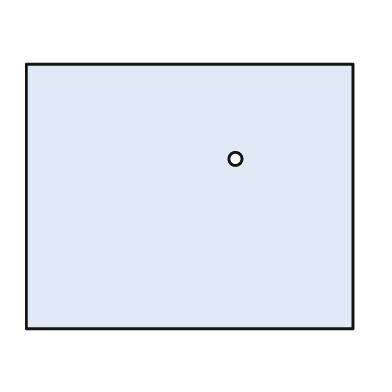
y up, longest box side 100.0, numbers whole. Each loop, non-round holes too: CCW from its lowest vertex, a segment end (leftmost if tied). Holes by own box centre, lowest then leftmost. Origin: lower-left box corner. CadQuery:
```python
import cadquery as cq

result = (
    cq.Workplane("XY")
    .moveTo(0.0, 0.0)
    .lineTo(100.0, 0.0)
    .lineTo(100.0, 81.0)
    .lineTo(0.0, 81.0)
    .close()
    .moveTo(64.0, 52.0)
    .circle(2.0)
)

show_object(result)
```